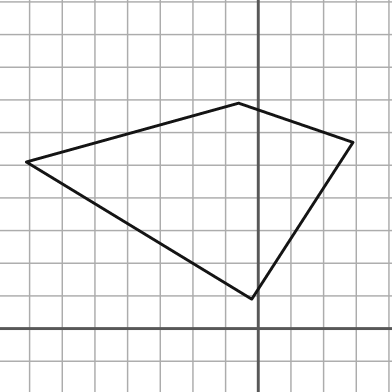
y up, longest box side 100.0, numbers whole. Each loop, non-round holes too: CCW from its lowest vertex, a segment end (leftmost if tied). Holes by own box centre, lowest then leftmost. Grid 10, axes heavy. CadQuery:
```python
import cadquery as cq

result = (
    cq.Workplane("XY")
    .moveTo(-2.0, 9.0)
    .lineTo(29.0, 57.0)
    .lineTo(-6.0, 69.0)
    .lineTo(-71.0, 51.0)
    .close()
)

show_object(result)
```